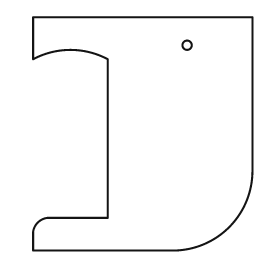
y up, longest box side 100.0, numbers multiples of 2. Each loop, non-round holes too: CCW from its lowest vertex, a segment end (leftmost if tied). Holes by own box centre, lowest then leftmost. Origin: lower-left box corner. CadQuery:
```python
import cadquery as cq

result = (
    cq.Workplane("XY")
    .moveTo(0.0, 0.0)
    .lineTo(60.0, 0.0)
    .threePointArc((84.0, 10.0), (94.0, 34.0))
    .lineTo(94.0, 100.0)
    .lineTo(0.0, 100.0)
    .lineTo(0.0, 82.0)
    .threePointArc((16.0, 86.0), (32.0, 82.0))
    .lineTo(32.0, 14.0)
    .lineTo(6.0, 14.0)
    .threePointArc((2.0, 12.0), (0.0, 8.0))
    .close()
    .moveTo(66.0, 88.0)
    .circle(2.0)
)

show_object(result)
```